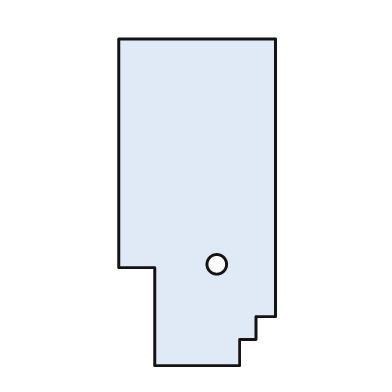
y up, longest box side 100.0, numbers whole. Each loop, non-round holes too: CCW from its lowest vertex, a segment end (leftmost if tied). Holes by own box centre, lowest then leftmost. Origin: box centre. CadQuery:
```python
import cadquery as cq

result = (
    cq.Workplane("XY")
    .moveTo(-13.0, -50.0)
    .lineTo(13.0, -50.0)
    .lineTo(13.0, -42.0)
    .lineTo(18.0, -42.0)
    .lineTo(18.0, -35.0)
    .lineTo(24.0, -35.0)
    .lineTo(24.0, 50.0)
    .lineTo(-24.0, 50.0)
    .lineTo(-24.0, -20.0)
    .lineTo(-13.0, -20.0)
    .close()
    .moveTo(6.0, -19.0)
    .circle(3.0)
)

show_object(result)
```